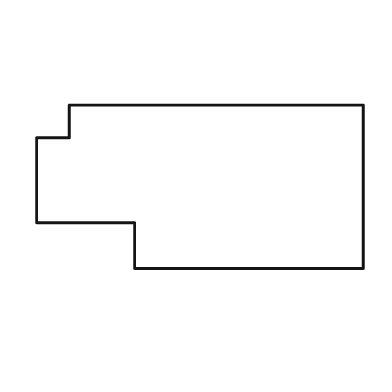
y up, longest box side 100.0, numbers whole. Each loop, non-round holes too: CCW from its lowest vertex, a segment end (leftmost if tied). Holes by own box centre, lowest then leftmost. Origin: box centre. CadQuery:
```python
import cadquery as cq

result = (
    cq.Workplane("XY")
    .moveTo(-20.0, -25.0)
    .lineTo(50.0, -25.0)
    .lineTo(50.0, 25.0)
    .lineTo(-40.0, 25.0)
    .lineTo(-40.0, 15.0)
    .lineTo(-50.0, 15.0)
    .lineTo(-50.0, -11.0)
    .lineTo(-20.0, -11.0)
    .close()
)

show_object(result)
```